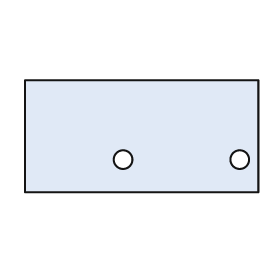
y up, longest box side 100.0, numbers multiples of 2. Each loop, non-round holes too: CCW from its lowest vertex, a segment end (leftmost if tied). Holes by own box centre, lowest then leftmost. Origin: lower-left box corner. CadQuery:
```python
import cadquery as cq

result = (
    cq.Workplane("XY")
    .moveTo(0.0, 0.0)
    .lineTo(100.0, 0.0)
    .lineTo(100.0, 48.0)
    .lineTo(0.0, 48.0)
    .close()
    .moveTo(42.0, 14.0)
    .circle(4.0)
    .moveTo(92.0, 14.0)
    .circle(4.0)
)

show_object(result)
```